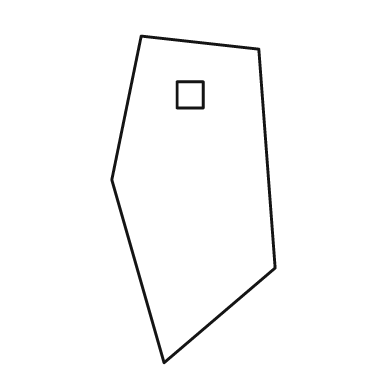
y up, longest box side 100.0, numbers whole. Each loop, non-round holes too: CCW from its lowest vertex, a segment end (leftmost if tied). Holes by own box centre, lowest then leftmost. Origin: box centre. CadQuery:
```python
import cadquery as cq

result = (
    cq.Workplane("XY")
    .moveTo(-9.0, -50.0)
    .lineTo(25.0, -21.0)
    .lineTo(20.0, 46.0)
    .lineTo(-16.0, 50.0)
    .lineTo(-25.0, 6.0)
    .close()
    .moveTo(-5.0, 28.0)
    .lineTo(3.0, 28.0)
    .lineTo(3.0, 36.0)
    .lineTo(-5.0, 36.0)
    .close()
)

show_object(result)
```